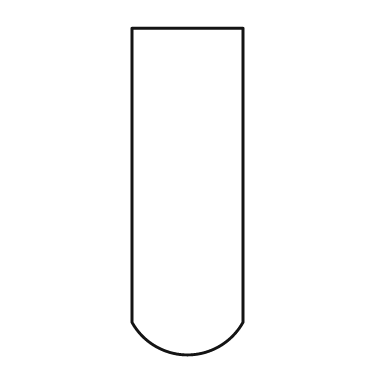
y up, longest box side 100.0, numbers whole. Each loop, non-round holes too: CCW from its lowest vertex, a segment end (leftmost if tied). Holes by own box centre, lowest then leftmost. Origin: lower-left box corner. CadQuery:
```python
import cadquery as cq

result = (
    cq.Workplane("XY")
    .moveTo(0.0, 10.0)
    .threePointArc((17.0, 0.0), (34.0, 10.0))
    .lineTo(34.0, 100.0)
    .lineTo(0.0, 100.0)
    .close()
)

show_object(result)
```